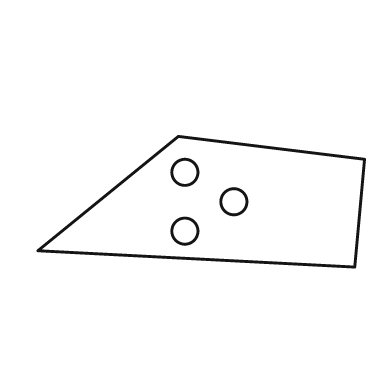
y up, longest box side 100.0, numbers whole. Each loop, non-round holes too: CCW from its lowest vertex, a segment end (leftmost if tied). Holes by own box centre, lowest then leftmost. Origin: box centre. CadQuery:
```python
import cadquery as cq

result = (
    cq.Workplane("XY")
    .moveTo(47.0, -20.0)
    .lineTo(50.0, 13.0)
    .lineTo(-7.0, 20.0)
    .lineTo(-50.0, -15.0)
    .close()
    .moveTo(-5.0, -9.0)
    .circle(4.0)
    .moveTo(10.0, 0.0)
    .circle(4.0)
    .moveTo(-5.0, 9.0)
    .circle(4.0)
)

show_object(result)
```